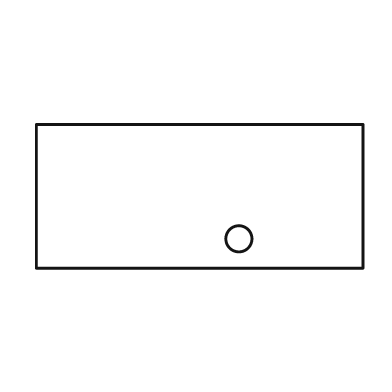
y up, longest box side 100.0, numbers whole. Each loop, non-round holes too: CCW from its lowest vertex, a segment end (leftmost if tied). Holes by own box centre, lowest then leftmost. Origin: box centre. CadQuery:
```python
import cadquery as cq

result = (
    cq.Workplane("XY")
    .moveTo(-50.0, -22.0)
    .lineTo(50.0, -22.0)
    .lineTo(50.0, 22.0)
    .lineTo(-50.0, 22.0)
    .close()
    .moveTo(12.0, -13.0)
    .circle(4.0)
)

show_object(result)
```